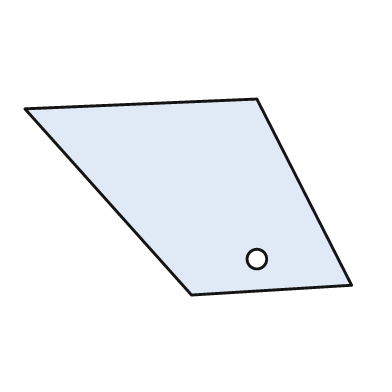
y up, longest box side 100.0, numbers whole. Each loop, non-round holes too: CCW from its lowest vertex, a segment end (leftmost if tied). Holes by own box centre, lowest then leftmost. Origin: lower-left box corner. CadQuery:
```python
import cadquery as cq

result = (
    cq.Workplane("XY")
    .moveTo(51.0, 0.0)
    .lineTo(100.0, 3.0)
    .lineTo(71.0, 60.0)
    .lineTo(0.0, 57.0)
    .close()
    .moveTo(71.0, 11.0)
    .circle(3.0)
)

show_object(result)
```